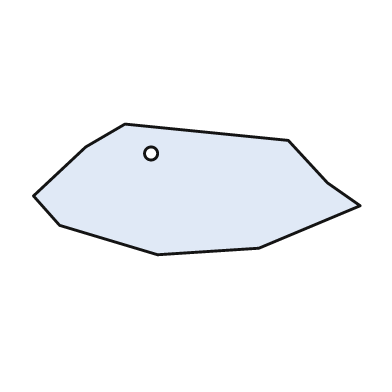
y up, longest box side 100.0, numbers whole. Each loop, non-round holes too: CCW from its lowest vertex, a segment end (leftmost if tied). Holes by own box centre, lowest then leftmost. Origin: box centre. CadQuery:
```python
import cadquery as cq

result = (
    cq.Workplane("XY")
    .moveTo(-12.0, -20.0)
    .lineTo(19.0, -18.0)
    .lineTo(50.0, -5.0)
    .lineTo(40.0, 2.0)
    .lineTo(28.0, 15.0)
    .lineTo(-22.0, 20.0)
    .lineTo(-34.0, 13.0)
    .lineTo(-50.0, -2.0)
    .lineTo(-42.0, -11.0)
    .close()
    .moveTo(-14.0, 11.0)
    .circle(2.0)
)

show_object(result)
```